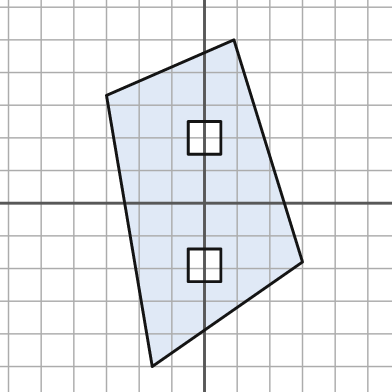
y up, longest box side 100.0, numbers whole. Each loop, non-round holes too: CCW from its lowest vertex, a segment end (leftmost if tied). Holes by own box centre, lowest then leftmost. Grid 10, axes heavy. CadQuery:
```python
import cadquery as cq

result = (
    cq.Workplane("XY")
    .moveTo(-16.0, -50.0)
    .lineTo(30.0, -18.0)
    .lineTo(9.0, 50.0)
    .lineTo(-30.0, 33.0)
    .close()
    .moveTo(-5.0, -24.0)
    .lineTo(5.0, -24.0)
    .lineTo(5.0, -14.0)
    .lineTo(-5.0, -14.0)
    .close()
    .moveTo(-5.0, 15.0)
    .lineTo(5.0, 15.0)
    .lineTo(5.0, 25.0)
    .lineTo(-5.0, 25.0)
    .close()
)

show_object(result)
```